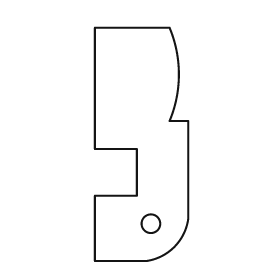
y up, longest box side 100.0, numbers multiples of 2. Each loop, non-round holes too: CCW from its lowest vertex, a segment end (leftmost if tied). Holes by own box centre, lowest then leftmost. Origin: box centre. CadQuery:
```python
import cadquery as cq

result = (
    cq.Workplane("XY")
    .moveTo(-20.0, -50.0)
    .lineTo(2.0, -50.0)
    .threePointArc((14.0, -44.0), (20.0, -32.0))
    .lineTo(20.0, 10.0)
    .lineTo(12.0, 10.0)
    .threePointArc((16.0, 30.0), (12.0, 50.0))
    .lineTo(-20.0, 50.0)
    .lineTo(-20.0, -2.0)
    .lineTo(-2.0, -2.0)
    .lineTo(-2.0, -22.0)
    .lineTo(-20.0, -22.0)
    .close()
    .moveTo(4.0, -34.0)
    .circle(4.0)
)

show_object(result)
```